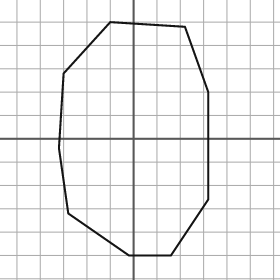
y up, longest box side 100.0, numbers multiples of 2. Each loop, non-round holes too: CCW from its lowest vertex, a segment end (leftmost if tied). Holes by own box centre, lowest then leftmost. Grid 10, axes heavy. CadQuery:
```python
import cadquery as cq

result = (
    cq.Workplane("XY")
    .moveTo(-2.0, -50.0)
    .lineTo(16.0, -50.0)
    .lineTo(32.0, -26.0)
    .lineTo(32.0, 20.0)
    .lineTo(22.0, 48.0)
    .lineTo(-10.0, 50.0)
    .lineTo(-30.0, 28.0)
    .lineTo(-32.0, -4.0)
    .lineTo(-28.0, -32.0)
    .close()
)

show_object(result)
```